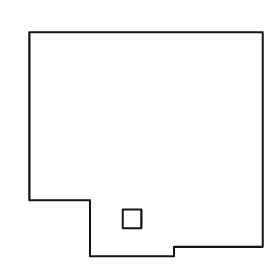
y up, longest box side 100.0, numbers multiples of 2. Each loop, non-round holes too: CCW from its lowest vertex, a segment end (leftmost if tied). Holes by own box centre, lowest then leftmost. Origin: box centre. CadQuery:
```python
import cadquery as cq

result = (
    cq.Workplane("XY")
    .moveTo(-24.0, -48.0)
    .lineTo(12.0, -48.0)
    .lineTo(12.0, -44.0)
    .lineTo(50.0, -44.0)
    .lineTo(50.0, 48.0)
    .lineTo(-50.0, 48.0)
    .lineTo(-50.0, -24.0)
    .lineTo(-24.0, -24.0)
    .close()
    .moveTo(-10.0, -36.0)
    .lineTo(-2.0, -36.0)
    .lineTo(-2.0, -28.0)
    .lineTo(-10.0, -28.0)
    .close()
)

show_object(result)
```